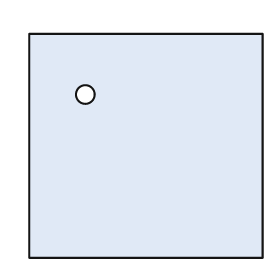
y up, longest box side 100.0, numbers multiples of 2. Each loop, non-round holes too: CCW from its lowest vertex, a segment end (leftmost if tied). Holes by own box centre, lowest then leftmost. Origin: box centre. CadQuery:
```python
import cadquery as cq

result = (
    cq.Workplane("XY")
    .moveTo(-50.0, -48.0)
    .lineTo(50.0, -48.0)
    .lineTo(50.0, 48.0)
    .lineTo(-50.0, 48.0)
    .close()
    .moveTo(-26.0, 22.0)
    .circle(4.0)
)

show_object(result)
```